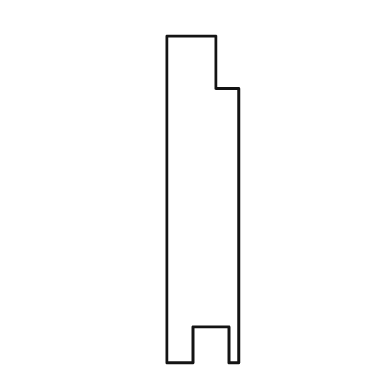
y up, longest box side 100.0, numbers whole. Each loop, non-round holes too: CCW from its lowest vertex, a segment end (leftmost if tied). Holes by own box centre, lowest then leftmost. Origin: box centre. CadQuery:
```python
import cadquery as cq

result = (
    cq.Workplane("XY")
    .moveTo(-11.0, -50.0)
    .lineTo(-3.0, -50.0)
    .lineTo(-3.0, -39.0)
    .lineTo(8.0, -39.0)
    .lineTo(8.0, -50.0)
    .lineTo(11.0, -50.0)
    .lineTo(11.0, 34.0)
    .lineTo(4.0, 34.0)
    .lineTo(4.0, 50.0)
    .lineTo(-11.0, 50.0)
    .close()
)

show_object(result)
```